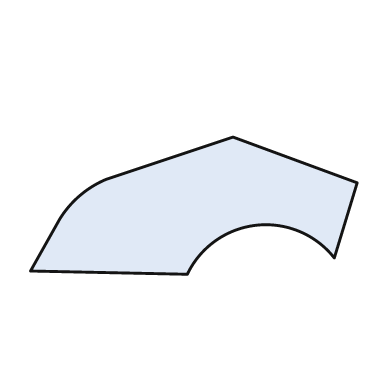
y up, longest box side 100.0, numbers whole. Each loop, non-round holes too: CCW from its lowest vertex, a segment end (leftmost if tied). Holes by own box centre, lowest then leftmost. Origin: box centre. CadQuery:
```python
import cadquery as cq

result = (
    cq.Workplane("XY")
    .moveTo(-2.0, -21.0)
    .threePointArc((19.0, -6.0), (43.0, -16.0))
    .lineTo(50.0, 7.0)
    .lineTo(12.0, 21.0)
    .lineTo(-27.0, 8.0)
    .threePointArc((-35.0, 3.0), (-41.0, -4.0))
    .lineTo(-50.0, -20.0)
    .close()
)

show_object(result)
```